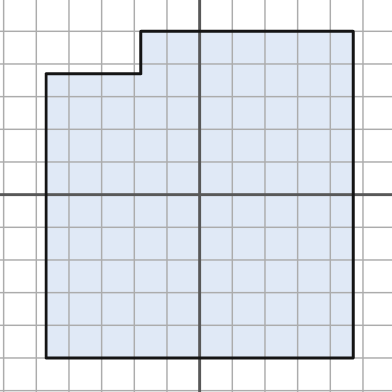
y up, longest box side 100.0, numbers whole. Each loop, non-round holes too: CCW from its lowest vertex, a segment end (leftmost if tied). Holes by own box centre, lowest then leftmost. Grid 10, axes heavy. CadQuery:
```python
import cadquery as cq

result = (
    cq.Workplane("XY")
    .moveTo(-47.0, -50.0)
    .lineTo(47.0, -50.0)
    .lineTo(47.0, 50.0)
    .lineTo(-18.0, 50.0)
    .lineTo(-18.0, 37.0)
    .lineTo(-47.0, 37.0)
    .close()
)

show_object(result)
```